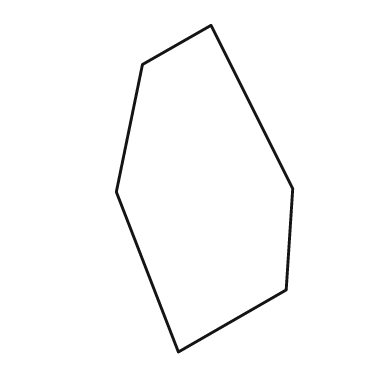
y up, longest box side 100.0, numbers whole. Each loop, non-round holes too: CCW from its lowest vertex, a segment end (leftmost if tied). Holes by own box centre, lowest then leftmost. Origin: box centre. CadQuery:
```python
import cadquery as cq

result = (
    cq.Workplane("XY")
    .moveTo(-8.0, -50.0)
    .lineTo(25.0, -31.0)
    .lineTo(27.0, 0.0)
    .lineTo(2.0, 50.0)
    .lineTo(-19.0, 38.0)
    .lineTo(-27.0, -1.0)
    .close()
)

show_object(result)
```